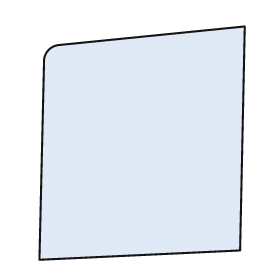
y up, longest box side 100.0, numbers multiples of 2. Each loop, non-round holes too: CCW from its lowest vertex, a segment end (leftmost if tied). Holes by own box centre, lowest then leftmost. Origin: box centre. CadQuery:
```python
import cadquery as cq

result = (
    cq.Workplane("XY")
    .moveTo(-44.0, -50.0)
    .lineTo(42.0, -46.0)
    .lineTo(44.0, 50.0)
    .lineTo(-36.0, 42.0)
    .threePointArc((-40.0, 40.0), (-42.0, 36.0))
    .close()
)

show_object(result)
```